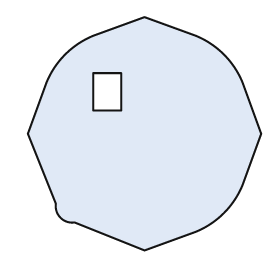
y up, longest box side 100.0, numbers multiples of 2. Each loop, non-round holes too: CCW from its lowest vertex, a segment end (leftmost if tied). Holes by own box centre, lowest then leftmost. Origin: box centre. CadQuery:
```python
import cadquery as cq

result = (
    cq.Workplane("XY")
    .moveTo(0.0, -50.0)
    .lineTo(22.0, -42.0)
    .threePointArc((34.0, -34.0), (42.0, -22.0))
    .lineTo(50.0, 0.0)
    .lineTo(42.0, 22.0)
    .threePointArc((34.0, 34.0), (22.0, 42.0))
    .lineTo(0.0, 50.0)
    .lineTo(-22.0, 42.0)
    .threePointArc((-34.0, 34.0), (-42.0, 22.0))
    .lineTo(-50.0, 0.0)
    .lineTo(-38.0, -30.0)
    .threePointArc((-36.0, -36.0), (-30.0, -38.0))
    .close()
    .moveTo(-22.0, 10.0)
    .lineTo(-10.0, 10.0)
    .lineTo(-10.0, 26.0)
    .lineTo(-22.0, 26.0)
    .close()
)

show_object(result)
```